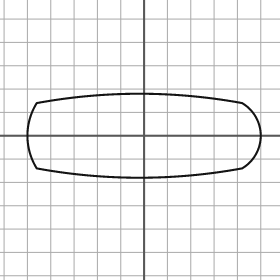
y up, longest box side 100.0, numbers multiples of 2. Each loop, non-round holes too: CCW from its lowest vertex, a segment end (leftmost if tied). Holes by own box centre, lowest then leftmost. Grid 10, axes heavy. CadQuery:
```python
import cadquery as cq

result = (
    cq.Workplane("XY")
    .moveTo(-46.0, -14.0)
    .threePointArc((-2.0, -18.0), (42.0, -14.0))
    .threePointArc((50.0, 0.0), (42.0, 14.0))
    .threePointArc((-2.0, 18.0), (-46.0, 14.0))
    .threePointArc((-50.0, 0.0), (-46.0, -14.0))
    .close()
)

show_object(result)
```